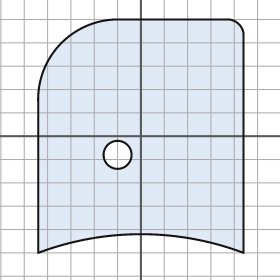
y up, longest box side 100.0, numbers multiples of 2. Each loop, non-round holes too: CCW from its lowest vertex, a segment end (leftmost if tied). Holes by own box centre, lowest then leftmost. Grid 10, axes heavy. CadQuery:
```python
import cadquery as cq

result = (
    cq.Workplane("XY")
    .moveTo(-44.0, -50.0)
    .threePointArc((0.0, -42.0), (44.0, -50.0))
    .lineTo(44.0, 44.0)
    .threePointArc((42.0, 48.0), (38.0, 50.0))
    .lineTo(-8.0, 50.0)
    .threePointArc((-34.0, 40.0), (-44.0, 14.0))
    .close()
    .moveTo(-10.0, -8.0)
    .circle(6.0)
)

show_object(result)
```